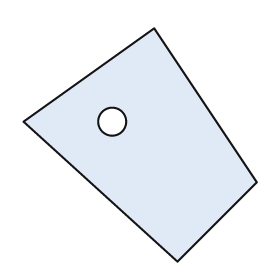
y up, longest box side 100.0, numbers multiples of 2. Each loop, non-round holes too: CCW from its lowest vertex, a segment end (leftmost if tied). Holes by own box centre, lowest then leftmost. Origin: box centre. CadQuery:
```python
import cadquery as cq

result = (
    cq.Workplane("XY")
    .moveTo(16.0, -50.0)
    .lineTo(50.0, -16.0)
    .lineTo(6.0, 50.0)
    .lineTo(-50.0, 10.0)
    .close()
    .moveTo(-12.0, 10.0)
    .circle(6.0)
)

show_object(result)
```